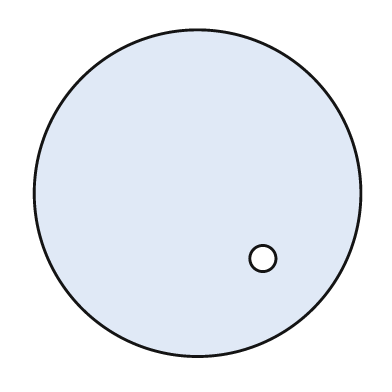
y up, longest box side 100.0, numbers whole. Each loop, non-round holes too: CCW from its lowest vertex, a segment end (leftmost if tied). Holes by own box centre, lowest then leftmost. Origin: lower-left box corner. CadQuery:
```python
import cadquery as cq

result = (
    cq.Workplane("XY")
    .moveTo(50.0, 50.0)
    .circle(50.0)
    .moveTo(70.0, 30.0)
    .circle(4.0)
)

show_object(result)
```